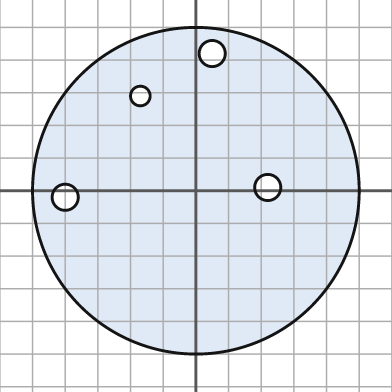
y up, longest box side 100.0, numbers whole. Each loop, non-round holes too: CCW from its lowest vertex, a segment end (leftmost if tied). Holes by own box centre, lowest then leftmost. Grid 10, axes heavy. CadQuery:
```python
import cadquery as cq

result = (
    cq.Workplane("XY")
    .moveTo(0.0, 0.0)
    .circle(50.0)
    .moveTo(-40.0, -2.0)
    .circle(4.0)
    .moveTo(22.0, 1.0)
    .circle(4.0)
    .moveTo(-17.0, 29.0)
    .circle(3.0)
    .moveTo(5.0, 42.0)
    .circle(4.0)
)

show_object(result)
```